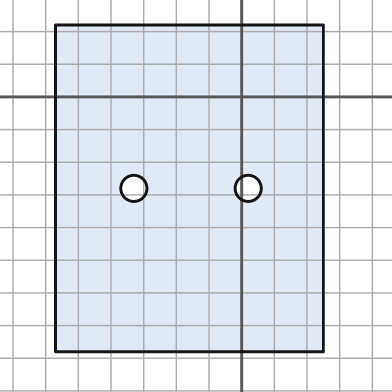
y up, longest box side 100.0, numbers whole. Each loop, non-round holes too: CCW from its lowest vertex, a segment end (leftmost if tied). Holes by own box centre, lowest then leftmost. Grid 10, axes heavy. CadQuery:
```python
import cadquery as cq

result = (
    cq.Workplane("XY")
    .moveTo(-57.0, -78.0)
    .lineTo(25.0, -78.0)
    .lineTo(25.0, 22.0)
    .lineTo(-57.0, 22.0)
    .close()
    .moveTo(-33.0, -28.0)
    .circle(4.0)
    .moveTo(2.0, -28.0)
    .circle(4.0)
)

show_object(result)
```